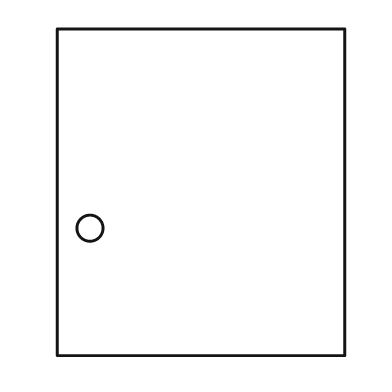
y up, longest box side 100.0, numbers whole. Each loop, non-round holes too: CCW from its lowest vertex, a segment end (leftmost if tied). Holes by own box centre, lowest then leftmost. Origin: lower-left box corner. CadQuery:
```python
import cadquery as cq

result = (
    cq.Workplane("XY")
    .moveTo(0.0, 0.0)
    .lineTo(88.0, 0.0)
    .lineTo(88.0, 100.0)
    .lineTo(0.0, 100.0)
    .close()
    .moveTo(10.0, 39.0)
    .circle(4.0)
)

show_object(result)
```